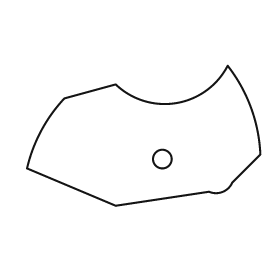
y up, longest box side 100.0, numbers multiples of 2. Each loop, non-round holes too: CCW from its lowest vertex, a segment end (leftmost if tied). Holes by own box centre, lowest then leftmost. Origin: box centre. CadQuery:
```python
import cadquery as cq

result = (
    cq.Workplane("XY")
    .moveTo(-12.0, -30.0)
    .lineTo(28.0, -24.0)
    .threePointArc((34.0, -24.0), (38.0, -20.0))
    .lineTo(50.0, -8.0)
    .threePointArc((46.0, 12.0), (36.0, 30.0))
    .threePointArc((14.0, 14.0), (-12.0, 22.0))
    .lineTo(-34.0, 16.0)
    .threePointArc((-44.0, 2.0), (-50.0, -14.0))
    .close()
    .moveTo(8.0, -10.0)
    .circle(4.0)
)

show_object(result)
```